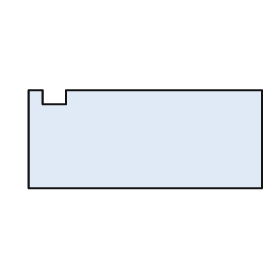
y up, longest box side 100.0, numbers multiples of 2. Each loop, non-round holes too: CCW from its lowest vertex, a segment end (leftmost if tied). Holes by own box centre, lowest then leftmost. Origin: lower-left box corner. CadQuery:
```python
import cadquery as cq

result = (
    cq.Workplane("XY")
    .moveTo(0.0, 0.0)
    .lineTo(100.0, 0.0)
    .lineTo(100.0, 42.0)
    .lineTo(16.0, 42.0)
    .lineTo(16.0, 36.0)
    .lineTo(6.0, 36.0)
    .lineTo(6.0, 42.0)
    .lineTo(0.0, 42.0)
    .close()
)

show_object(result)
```